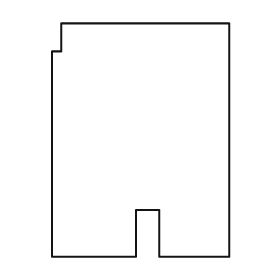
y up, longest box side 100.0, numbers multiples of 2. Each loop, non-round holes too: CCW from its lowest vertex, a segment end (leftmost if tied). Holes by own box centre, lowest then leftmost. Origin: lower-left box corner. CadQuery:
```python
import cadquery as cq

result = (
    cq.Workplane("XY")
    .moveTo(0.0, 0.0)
    .lineTo(36.0, 0.0)
    .lineTo(36.0, 20.0)
    .lineTo(46.0, 20.0)
    .lineTo(46.0, 0.0)
    .lineTo(76.0, 0.0)
    .lineTo(76.0, 100.0)
    .lineTo(4.0, 100.0)
    .lineTo(4.0, 88.0)
    .lineTo(0.0, 88.0)
    .close()
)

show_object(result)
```